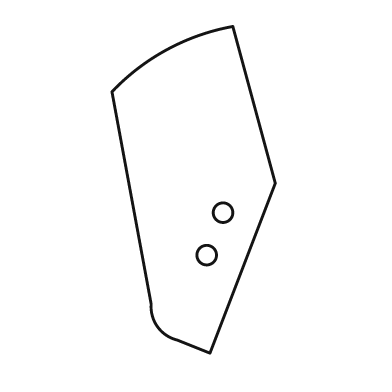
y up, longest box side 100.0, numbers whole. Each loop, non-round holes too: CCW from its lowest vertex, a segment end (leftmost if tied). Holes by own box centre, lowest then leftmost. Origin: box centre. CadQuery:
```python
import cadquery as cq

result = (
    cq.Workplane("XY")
    .moveTo(5.0, -50.0)
    .lineTo(25.0, 2.0)
    .lineTo(12.0, 50.0)
    .threePointArc((-8.0, 43.0), (-25.0, 30.0))
    .lineTo(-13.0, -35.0)
    .threePointArc((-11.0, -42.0), (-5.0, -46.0))
    .close()
    .moveTo(4.0, -20.0)
    .circle(3.0)
    .moveTo(9.0, -7.0)
    .circle(3.0)
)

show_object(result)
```